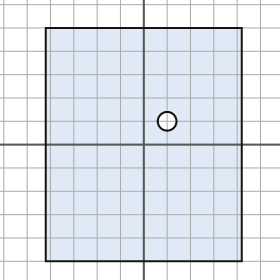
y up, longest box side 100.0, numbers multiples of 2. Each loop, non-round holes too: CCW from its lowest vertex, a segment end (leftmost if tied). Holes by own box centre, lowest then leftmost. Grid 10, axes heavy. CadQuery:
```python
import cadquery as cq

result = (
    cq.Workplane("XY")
    .moveTo(-42.0, -50.0)
    .lineTo(42.0, -50.0)
    .lineTo(42.0, 50.0)
    .lineTo(-42.0, 50.0)
    .close()
    .moveTo(10.0, 10.0)
    .circle(4.0)
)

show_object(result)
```